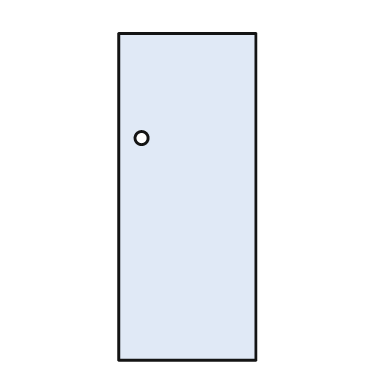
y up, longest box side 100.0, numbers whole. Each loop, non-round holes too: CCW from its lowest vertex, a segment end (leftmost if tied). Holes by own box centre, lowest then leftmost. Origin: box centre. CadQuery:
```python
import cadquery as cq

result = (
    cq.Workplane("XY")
    .moveTo(-21.0, -50.0)
    .lineTo(21.0, -50.0)
    .lineTo(21.0, 50.0)
    .lineTo(-21.0, 50.0)
    .close()
    .moveTo(-14.0, 18.0)
    .circle(2.0)
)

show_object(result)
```